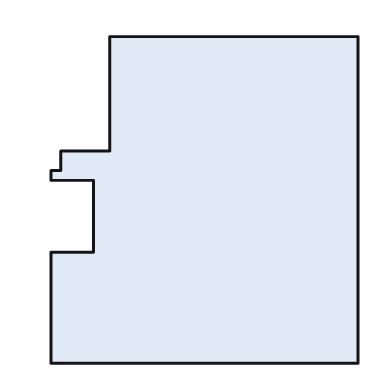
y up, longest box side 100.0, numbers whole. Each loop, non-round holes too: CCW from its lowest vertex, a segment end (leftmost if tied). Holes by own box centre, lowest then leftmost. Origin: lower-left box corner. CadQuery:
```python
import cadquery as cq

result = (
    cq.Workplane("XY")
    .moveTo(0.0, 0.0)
    .lineTo(94.0, 0.0)
    .lineTo(94.0, 100.0)
    .lineTo(18.0, 100.0)
    .lineTo(18.0, 65.0)
    .lineTo(3.0, 65.0)
    .lineTo(3.0, 59.0)
    .lineTo(0.0, 59.0)
    .lineTo(0.0, 56.0)
    .lineTo(13.0, 56.0)
    .lineTo(13.0, 34.0)
    .lineTo(0.0, 34.0)
    .close()
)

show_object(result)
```